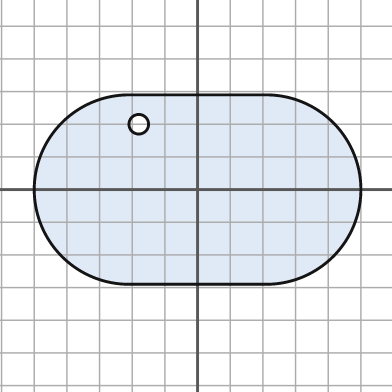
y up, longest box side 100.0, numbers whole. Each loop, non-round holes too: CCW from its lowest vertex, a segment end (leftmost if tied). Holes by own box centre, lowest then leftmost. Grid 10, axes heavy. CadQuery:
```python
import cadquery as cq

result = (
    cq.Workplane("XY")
    .moveTo(-21.0, -29.0)
    .lineTo(21.0, -29.0)
    .threePointArc((50.0, 0.0), (21.0, 29.0))
    .lineTo(-21.0, 29.0)
    .threePointArc((-50.0, 0.0), (-21.0, -29.0))
    .close()
    .moveTo(-18.0, 20.0)
    .circle(3.0)
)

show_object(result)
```